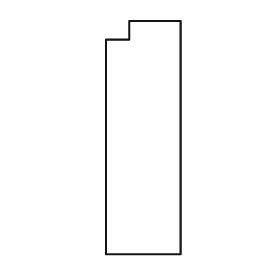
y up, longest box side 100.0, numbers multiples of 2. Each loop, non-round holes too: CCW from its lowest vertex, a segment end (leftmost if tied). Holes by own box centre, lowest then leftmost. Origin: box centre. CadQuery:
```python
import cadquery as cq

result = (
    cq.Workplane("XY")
    .moveTo(-16.0, -50.0)
    .lineTo(16.0, -50.0)
    .lineTo(16.0, 50.0)
    .lineTo(-6.0, 50.0)
    .lineTo(-6.0, 42.0)
    .lineTo(-16.0, 42.0)
    .close()
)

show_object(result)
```